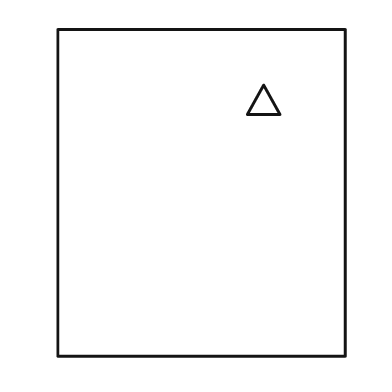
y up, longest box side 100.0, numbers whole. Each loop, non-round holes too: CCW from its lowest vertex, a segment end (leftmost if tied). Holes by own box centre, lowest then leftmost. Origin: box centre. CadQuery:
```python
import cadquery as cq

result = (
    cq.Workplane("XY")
    .moveTo(-44.0, -50.0)
    .lineTo(44.0, -50.0)
    .lineTo(44.0, 50.0)
    .lineTo(-44.0, 50.0)
    .close()
    .moveTo(14.0, 24.0)
    .lineTo(24.0, 24.0)
    .lineTo(19.0, 33.0)
    .close()
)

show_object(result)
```